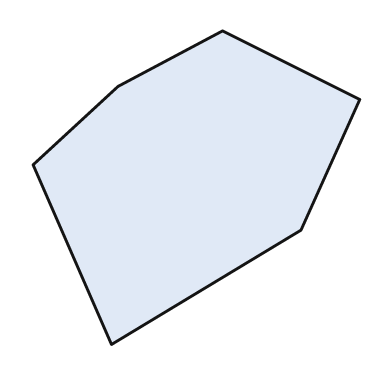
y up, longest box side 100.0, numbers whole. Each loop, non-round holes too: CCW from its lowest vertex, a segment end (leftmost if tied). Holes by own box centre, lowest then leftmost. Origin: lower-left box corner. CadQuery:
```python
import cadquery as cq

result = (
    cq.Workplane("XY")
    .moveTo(24.0, 0.0)
    .lineTo(82.0, 35.0)
    .lineTo(100.0, 75.0)
    .lineTo(58.0, 96.0)
    .lineTo(26.0, 79.0)
    .lineTo(0.0, 55.0)
    .close()
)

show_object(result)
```